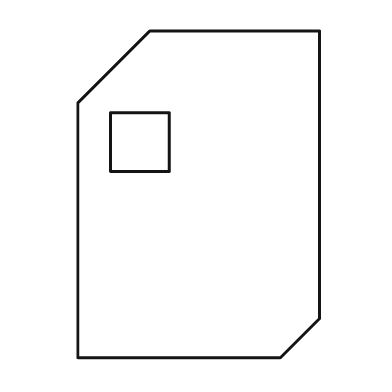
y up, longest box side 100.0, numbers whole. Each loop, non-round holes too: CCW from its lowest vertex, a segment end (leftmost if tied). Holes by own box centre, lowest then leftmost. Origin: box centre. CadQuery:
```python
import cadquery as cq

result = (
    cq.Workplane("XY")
    .moveTo(-37.0, -50.0)
    .lineTo(25.0, -50.0)
    .lineTo(37.0, -38.0)
    .lineTo(37.0, 50.0)
    .lineTo(-15.0, 50.0)
    .lineTo(-37.0, 28.0)
    .close()
    .moveTo(-27.0, 7.0)
    .lineTo(-9.0, 7.0)
    .lineTo(-9.0, 25.0)
    .lineTo(-27.0, 25.0)
    .close()
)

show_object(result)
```